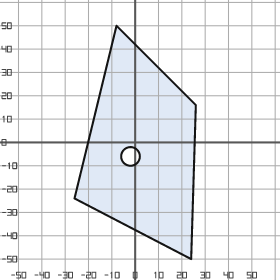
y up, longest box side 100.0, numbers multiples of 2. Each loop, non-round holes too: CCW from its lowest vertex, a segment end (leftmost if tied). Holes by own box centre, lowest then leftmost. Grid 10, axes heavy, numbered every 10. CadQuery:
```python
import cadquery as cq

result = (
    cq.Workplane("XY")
    .moveTo(24.0, -50.0)
    .lineTo(26.0, 16.0)
    .lineTo(-8.0, 50.0)
    .lineTo(-26.0, -24.0)
    .close()
    .moveTo(-2.0, -6.0)
    .circle(4.0)
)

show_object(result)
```